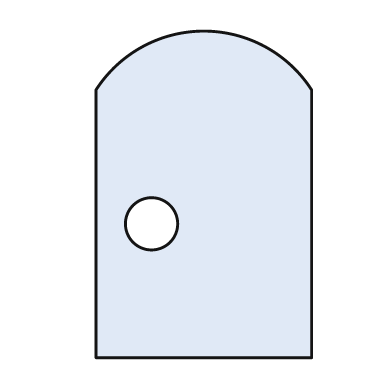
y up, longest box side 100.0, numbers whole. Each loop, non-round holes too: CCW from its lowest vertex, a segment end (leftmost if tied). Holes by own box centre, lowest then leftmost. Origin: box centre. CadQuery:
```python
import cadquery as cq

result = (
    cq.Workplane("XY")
    .moveTo(-33.0, -50.0)
    .lineTo(33.0, -50.0)
    .lineTo(33.0, 32.0)
    .threePointArc((0.0, 50.0), (-33.0, 32.0))
    .close()
    .moveTo(-16.0, -9.0)
    .circle(8.0)
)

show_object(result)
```